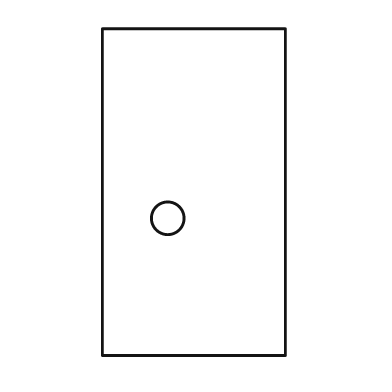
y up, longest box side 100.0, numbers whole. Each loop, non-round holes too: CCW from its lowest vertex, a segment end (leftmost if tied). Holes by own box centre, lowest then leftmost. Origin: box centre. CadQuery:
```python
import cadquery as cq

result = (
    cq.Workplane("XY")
    .moveTo(-28.0, -50.0)
    .lineTo(28.0, -50.0)
    .lineTo(28.0, 50.0)
    .lineTo(-28.0, 50.0)
    .close()
    .moveTo(-8.0, -8.0)
    .circle(5.0)
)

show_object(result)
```